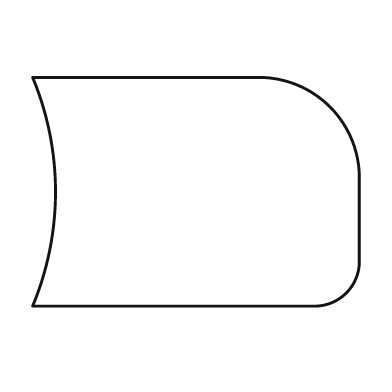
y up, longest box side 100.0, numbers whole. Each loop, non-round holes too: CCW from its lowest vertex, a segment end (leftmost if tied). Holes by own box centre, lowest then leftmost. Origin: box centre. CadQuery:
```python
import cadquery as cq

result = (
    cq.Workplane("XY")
    .moveTo(-50.0, -35.0)
    .lineTo(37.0, -35.0)
    .threePointArc((46.0, -31.0), (50.0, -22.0))
    .lineTo(50.0, 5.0)
    .threePointArc((41.0, 26.0), (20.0, 35.0))
    .lineTo(-50.0, 35.0)
    .threePointArc((-43.0, 0.0), (-50.0, -35.0))
    .close()
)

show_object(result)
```